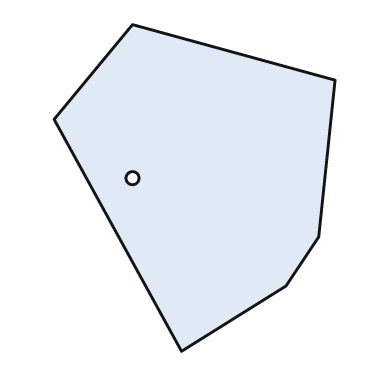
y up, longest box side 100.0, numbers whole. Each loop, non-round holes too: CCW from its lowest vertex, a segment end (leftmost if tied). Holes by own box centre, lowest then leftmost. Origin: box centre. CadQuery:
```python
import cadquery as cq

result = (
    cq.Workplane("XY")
    .moveTo(-4.0, -50.0)
    .lineTo(28.0, -30.0)
    .lineTo(38.0, -15.0)
    .lineTo(43.0, 33.0)
    .lineTo(-19.0, 50.0)
    .lineTo(-43.0, 21.0)
    .close()
    .moveTo(-19.0, 3.0)
    .circle(2.0)
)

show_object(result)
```